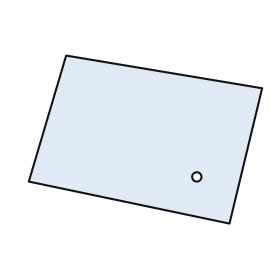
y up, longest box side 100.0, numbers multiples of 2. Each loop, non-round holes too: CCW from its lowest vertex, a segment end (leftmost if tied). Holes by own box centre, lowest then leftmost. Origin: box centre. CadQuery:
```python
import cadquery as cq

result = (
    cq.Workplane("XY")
    .moveTo(36.0, -36.0)
    .lineTo(50.0, 22.0)
    .lineTo(-34.0, 36.0)
    .lineTo(-50.0, -18.0)
    .close()
    .moveTo(22.0, -16.0)
    .circle(2.0)
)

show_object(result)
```